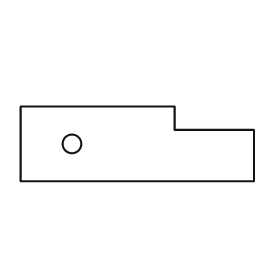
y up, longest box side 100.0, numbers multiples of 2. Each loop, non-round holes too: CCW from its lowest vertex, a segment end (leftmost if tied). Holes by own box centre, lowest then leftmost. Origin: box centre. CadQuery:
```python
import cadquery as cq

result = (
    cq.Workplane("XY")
    .moveTo(-50.0, -16.0)
    .lineTo(50.0, -16.0)
    .lineTo(50.0, 6.0)
    .lineTo(16.0, 6.0)
    .lineTo(16.0, 16.0)
    .lineTo(-50.0, 16.0)
    .close()
    .moveTo(-28.0, 0.0)
    .circle(4.0)
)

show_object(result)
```